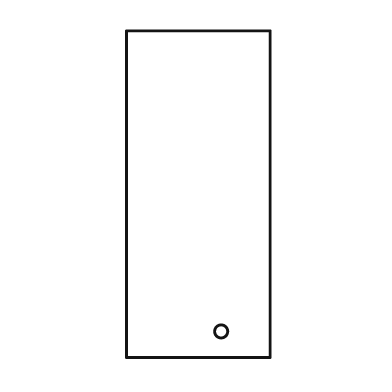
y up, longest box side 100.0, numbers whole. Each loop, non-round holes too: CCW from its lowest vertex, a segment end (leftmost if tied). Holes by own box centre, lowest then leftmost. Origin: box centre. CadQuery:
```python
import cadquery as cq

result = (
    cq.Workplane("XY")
    .moveTo(-22.0, -50.0)
    .lineTo(22.0, -50.0)
    .lineTo(22.0, 50.0)
    .lineTo(-22.0, 50.0)
    .close()
    .moveTo(7.0, -42.0)
    .circle(2.0)
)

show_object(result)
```